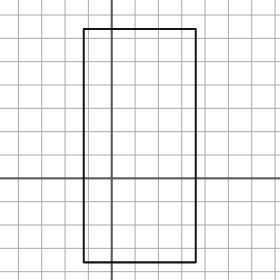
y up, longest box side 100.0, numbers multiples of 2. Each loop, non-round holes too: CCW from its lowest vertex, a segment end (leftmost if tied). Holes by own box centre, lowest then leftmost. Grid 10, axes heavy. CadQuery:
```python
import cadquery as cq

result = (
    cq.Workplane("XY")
    .moveTo(-12.0, -36.0)
    .lineTo(36.0, -36.0)
    .lineTo(36.0, 64.0)
    .lineTo(-12.0, 64.0)
    .close()
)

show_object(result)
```